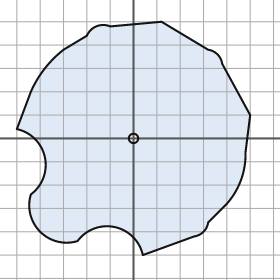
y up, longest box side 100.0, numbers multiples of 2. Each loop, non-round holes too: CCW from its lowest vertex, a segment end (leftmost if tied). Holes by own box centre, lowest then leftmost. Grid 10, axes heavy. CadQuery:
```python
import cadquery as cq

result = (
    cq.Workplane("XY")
    .moveTo(4.0, -50.0)
    .lineTo(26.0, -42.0)
    .threePointArc((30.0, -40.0), (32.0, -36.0))
    .lineTo(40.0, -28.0)
    .threePointArc((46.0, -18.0), (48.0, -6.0))
    .lineTo(50.0, 10.0)
    .lineTo(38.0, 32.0)
    .threePointArc((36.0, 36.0), (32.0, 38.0))
    .lineTo(12.0, 50.0)
    .lineTo(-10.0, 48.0)
    .threePointArc((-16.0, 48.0), (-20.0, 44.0))
    .lineTo(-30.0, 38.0)
    .threePointArc((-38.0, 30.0), (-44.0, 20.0))
    .lineTo(-50.0, 4.0)
    .threePointArc((-38.0, -8.0), (-44.0, -24.0))
    .threePointArc((-40.0, -40.0), (-24.0, -44.0))
    .threePointArc((-8.0, -38.0), (4.0, -50.0))
    .close()
    .moveTo(0.0, 0.0)
    .circle(2.0)
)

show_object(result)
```